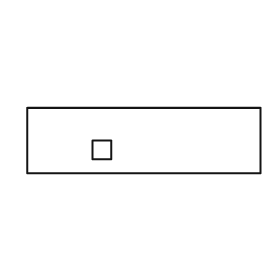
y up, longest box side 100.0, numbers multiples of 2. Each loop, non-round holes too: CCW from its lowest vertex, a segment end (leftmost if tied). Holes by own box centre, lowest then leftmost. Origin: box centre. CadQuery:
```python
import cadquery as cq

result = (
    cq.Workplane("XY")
    .moveTo(-50.0, -14.0)
    .lineTo(50.0, -14.0)
    .lineTo(50.0, 14.0)
    .lineTo(-50.0, 14.0)
    .close()
    .moveTo(-22.0, -8.0)
    .lineTo(-14.0, -8.0)
    .lineTo(-14.0, 0.0)
    .lineTo(-22.0, 0.0)
    .close()
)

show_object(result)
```